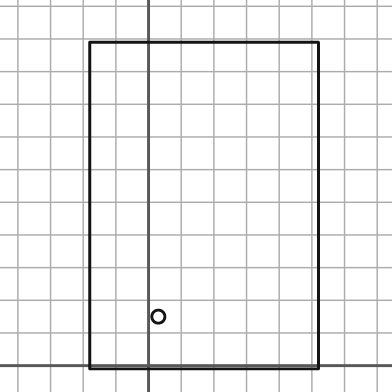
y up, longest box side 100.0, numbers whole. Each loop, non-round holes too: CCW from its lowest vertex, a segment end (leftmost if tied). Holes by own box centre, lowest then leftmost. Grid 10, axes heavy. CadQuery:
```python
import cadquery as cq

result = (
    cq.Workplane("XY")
    .moveTo(-18.0, -1.0)
    .lineTo(52.0, -1.0)
    .lineTo(52.0, 99.0)
    .lineTo(-18.0, 99.0)
    .close()
    .moveTo(3.0, 15.0)
    .circle(2.0)
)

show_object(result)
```